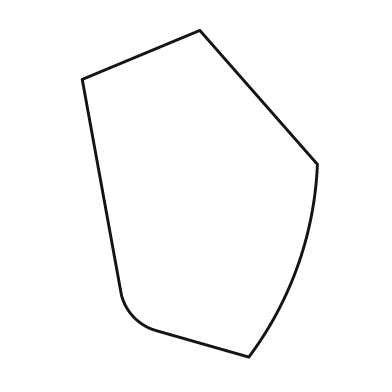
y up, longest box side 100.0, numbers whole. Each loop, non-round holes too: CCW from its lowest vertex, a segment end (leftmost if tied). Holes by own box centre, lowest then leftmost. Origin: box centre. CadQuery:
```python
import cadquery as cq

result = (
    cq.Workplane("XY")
    .moveTo(15.0, -50.0)
    .threePointArc((30.0, -22.0), (36.0, 9.0))
    .lineTo(0.0, 50.0)
    .lineTo(-36.0, 35.0)
    .lineTo(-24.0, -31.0)
    .threePointArc((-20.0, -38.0), (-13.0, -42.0))
    .close()
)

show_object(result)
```